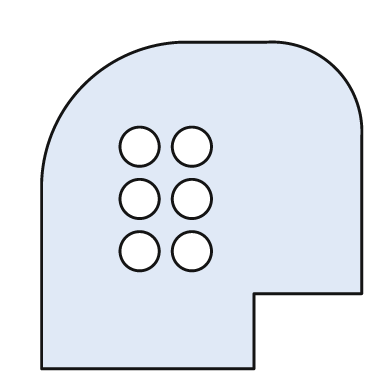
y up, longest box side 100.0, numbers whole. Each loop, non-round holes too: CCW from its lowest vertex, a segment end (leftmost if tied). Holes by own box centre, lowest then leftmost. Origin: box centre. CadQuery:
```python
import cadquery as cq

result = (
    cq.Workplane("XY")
    .moveTo(-49.0, -50.0)
    .lineTo(16.0, -50.0)
    .lineTo(16.0, -27.0)
    .lineTo(49.0, -27.0)
    .lineTo(49.0, 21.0)
    .threePointArc((41.0, 42.0), (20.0, 50.0))
    .lineTo(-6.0, 50.0)
    .threePointArc((-36.0, 37.0), (-49.0, 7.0))
    .close()
    .moveTo(-19.0, -14.0)
    .circle(6.0)
    .moveTo(-3.0, -14.0)
    .circle(6.0)
    .moveTo(-19.0, 2.0)
    .circle(6.0)
    .moveTo(-3.0, 2.0)
    .circle(6.0)
    .moveTo(-19.0, 18.0)
    .circle(6.0)
    .moveTo(-3.0, 18.0)
    .circle(6.0)
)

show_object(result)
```